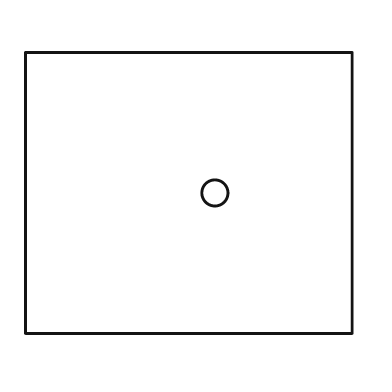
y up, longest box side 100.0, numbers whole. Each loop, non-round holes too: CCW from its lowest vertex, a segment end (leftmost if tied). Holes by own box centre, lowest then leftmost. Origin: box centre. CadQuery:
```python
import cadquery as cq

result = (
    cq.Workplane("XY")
    .moveTo(-50.0, -43.0)
    .lineTo(50.0, -43.0)
    .lineTo(50.0, 43.0)
    .lineTo(-50.0, 43.0)
    .close()
    .moveTo(8.0, 0.0)
    .circle(4.0)
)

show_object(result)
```